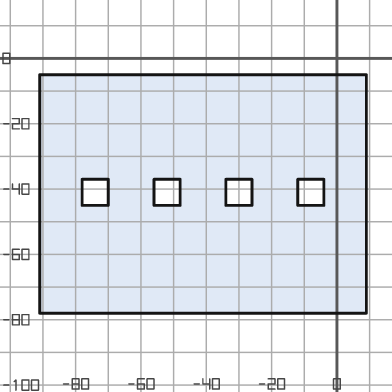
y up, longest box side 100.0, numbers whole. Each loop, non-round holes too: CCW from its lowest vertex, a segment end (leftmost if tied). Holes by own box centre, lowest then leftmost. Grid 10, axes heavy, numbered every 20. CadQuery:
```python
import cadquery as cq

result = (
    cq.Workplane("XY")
    .moveTo(-91.0, -78.0)
    .lineTo(9.0, -78.0)
    .lineTo(9.0, -5.0)
    .lineTo(-91.0, -5.0)
    .close()
    .moveTo(-78.0, -45.0)
    .lineTo(-70.0, -45.0)
    .lineTo(-70.0, -37.0)
    .lineTo(-78.0, -37.0)
    .close()
    .moveTo(-56.0, -45.0)
    .lineTo(-48.0, -45.0)
    .lineTo(-48.0, -37.0)
    .lineTo(-56.0, -37.0)
    .close()
    .moveTo(-34.0, -45.0)
    .lineTo(-26.0, -45.0)
    .lineTo(-26.0, -37.0)
    .lineTo(-34.0, -37.0)
    .close()
    .moveTo(-12.0, -45.0)
    .lineTo(-4.0, -45.0)
    .lineTo(-4.0, -37.0)
    .lineTo(-12.0, -37.0)
    .close()
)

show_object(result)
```